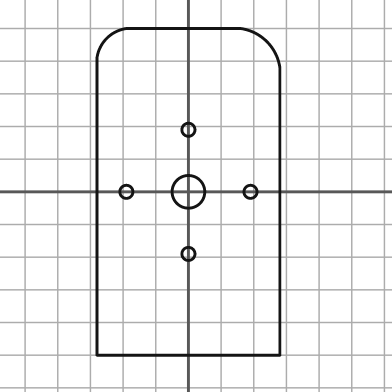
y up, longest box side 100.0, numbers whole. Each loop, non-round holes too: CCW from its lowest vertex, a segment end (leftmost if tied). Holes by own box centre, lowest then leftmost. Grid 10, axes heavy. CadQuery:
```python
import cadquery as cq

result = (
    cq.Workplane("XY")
    .moveTo(-28.0, -50.0)
    .lineTo(28.0, -50.0)
    .lineTo(28.0, 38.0)
    .threePointArc((24.0, 46.0), (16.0, 50.0))
    .lineTo(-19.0, 50.0)
    .threePointArc((-25.0, 47.0), (-28.0, 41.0))
    .close()
    .moveTo(0.0, -19.0)
    .circle(2.0)
    .moveTo(-19.0, 0.0)
    .circle(2.0)
    .moveTo(0.0, 0.0)
    .circle(5.0)
    .moveTo(19.0, 0.0)
    .circle(2.0)
    .moveTo(0.0, 19.0)
    .circle(2.0)
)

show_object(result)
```